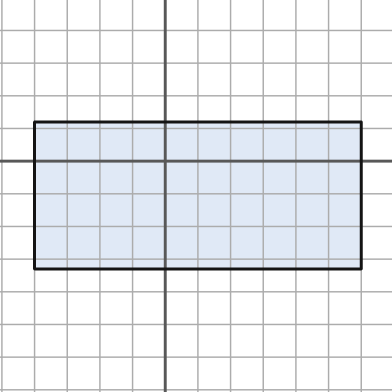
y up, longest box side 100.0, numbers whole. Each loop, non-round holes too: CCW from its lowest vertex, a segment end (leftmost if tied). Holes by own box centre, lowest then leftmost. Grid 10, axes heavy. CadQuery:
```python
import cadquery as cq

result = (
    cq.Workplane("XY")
    .moveTo(-40.0, -33.0)
    .lineTo(60.0, -33.0)
    .lineTo(60.0, 12.0)
    .lineTo(-40.0, 12.0)
    .close()
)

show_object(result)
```